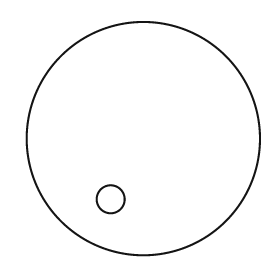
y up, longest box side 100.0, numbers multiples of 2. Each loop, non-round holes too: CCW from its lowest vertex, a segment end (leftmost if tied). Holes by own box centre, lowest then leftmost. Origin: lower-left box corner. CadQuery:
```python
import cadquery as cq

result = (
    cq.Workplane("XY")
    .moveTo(50.0, 50.0)
    .circle(50.0)
    .moveTo(36.0, 24.0)
    .circle(6.0)
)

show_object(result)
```